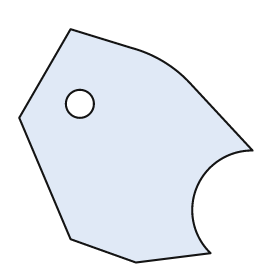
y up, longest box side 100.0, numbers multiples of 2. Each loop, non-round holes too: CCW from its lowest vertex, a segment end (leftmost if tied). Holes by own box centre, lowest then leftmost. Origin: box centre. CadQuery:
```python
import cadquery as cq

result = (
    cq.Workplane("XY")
    .moveTo(0.0, -50.0)
    .lineTo(32.0, -46.0)
    .threePointArc((26.0, -18.0), (50.0, -2.0))
    .lineTo(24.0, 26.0)
    .threePointArc((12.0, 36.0), (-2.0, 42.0))
    .lineTo(-28.0, 50.0)
    .lineTo(-50.0, 12.0)
    .lineTo(-28.0, -40.0)
    .close()
    .moveTo(-24.0, 18.0)
    .circle(6.0)
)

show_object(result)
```